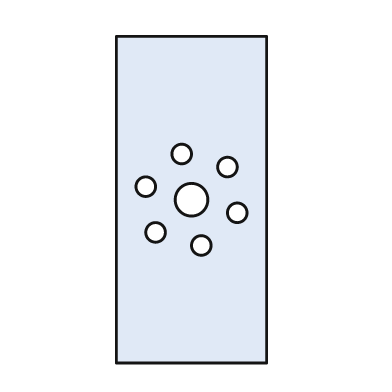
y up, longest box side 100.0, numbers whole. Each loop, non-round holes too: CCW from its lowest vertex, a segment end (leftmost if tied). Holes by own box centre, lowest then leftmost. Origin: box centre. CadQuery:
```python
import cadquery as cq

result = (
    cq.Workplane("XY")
    .moveTo(-23.0, -50.0)
    .lineTo(23.0, -50.0)
    .lineTo(23.0, 50.0)
    .lineTo(-23.0, 50.0)
    .close()
    .moveTo(3.0, -14.0)
    .circle(3.0)
    .moveTo(-11.0, -10.0)
    .circle(3.0)
    .moveTo(14.0, -4.0)
    .circle(3.0)
    .moveTo(0.0, 0.0)
    .circle(5.0)
    .moveTo(-14.0, 4.0)
    .circle(3.0)
    .moveTo(11.0, 10.0)
    .circle(3.0)
    .moveTo(-3.0, 14.0)
    .circle(3.0)
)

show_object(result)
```